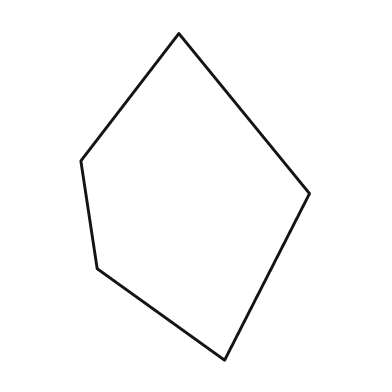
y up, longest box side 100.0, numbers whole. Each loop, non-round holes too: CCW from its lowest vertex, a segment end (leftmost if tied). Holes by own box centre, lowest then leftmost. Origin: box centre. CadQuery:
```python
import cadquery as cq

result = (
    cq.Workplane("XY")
    .moveTo(9.0, -50.0)
    .lineTo(35.0, 1.0)
    .lineTo(-5.0, 50.0)
    .lineTo(-35.0, 11.0)
    .lineTo(-30.0, -22.0)
    .close()
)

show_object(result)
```